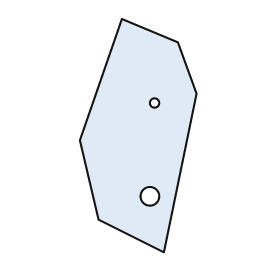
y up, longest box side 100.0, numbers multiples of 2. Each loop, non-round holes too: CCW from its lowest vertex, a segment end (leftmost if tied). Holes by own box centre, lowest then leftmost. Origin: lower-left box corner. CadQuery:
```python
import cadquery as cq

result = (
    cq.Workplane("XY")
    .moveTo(36.0, 0.0)
    .lineTo(50.0, 68.0)
    .lineTo(42.0, 90.0)
    .lineTo(18.0, 100.0)
    .lineTo(0.0, 48.0)
    .lineTo(8.0, 14.0)
    .close()
    .moveTo(30.0, 24.0)
    .circle(4.0)
    .moveTo(32.0, 64.0)
    .circle(2.0)
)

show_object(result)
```